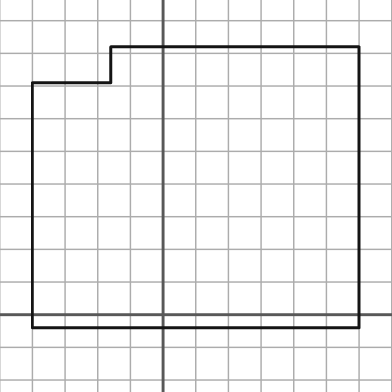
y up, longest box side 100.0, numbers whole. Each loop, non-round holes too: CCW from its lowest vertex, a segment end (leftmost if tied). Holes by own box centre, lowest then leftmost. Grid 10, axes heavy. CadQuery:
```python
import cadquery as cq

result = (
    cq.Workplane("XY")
    .moveTo(-40.0, -4.0)
    .lineTo(60.0, -4.0)
    .lineTo(60.0, 82.0)
    .lineTo(-16.0, 82.0)
    .lineTo(-16.0, 71.0)
    .lineTo(-40.0, 71.0)
    .close()
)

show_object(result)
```